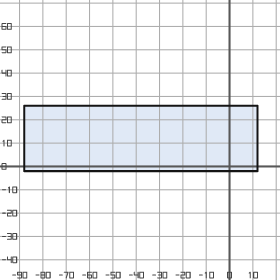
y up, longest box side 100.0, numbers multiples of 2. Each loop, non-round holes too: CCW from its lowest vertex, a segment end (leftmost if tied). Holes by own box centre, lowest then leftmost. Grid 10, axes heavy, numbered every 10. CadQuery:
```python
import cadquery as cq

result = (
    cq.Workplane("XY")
    .moveTo(-88.0, -2.0)
    .lineTo(12.0, -2.0)
    .lineTo(12.0, 26.0)
    .lineTo(-88.0, 26.0)
    .close()
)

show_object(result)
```